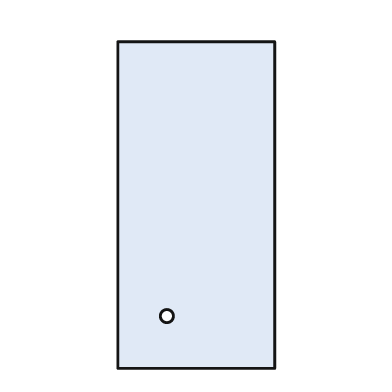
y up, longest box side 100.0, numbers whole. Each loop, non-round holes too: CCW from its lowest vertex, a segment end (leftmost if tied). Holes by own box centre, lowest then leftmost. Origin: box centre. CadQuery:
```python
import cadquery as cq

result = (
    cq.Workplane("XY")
    .moveTo(-24.0, -50.0)
    .lineTo(24.0, -50.0)
    .lineTo(24.0, 50.0)
    .lineTo(-24.0, 50.0)
    .close()
    .moveTo(-9.0, -34.0)
    .circle(2.0)
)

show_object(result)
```